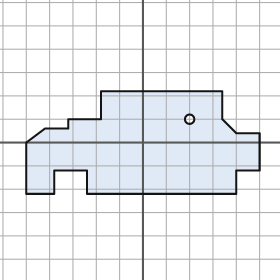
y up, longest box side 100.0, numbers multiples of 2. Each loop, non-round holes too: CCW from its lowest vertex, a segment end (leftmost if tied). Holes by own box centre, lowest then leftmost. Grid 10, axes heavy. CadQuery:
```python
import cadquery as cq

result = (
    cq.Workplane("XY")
    .moveTo(-50.0, -22.0)
    .lineTo(-38.0, -22.0)
    .lineTo(-38.0, -12.0)
    .lineTo(-24.0, -12.0)
    .lineTo(-24.0, -22.0)
    .lineTo(40.0, -22.0)
    .lineTo(40.0, -12.0)
    .lineTo(50.0, -12.0)
    .lineTo(50.0, 4.0)
    .lineTo(40.0, 4.0)
    .lineTo(34.0, 10.0)
    .lineTo(34.0, 22.0)
    .lineTo(-18.0, 22.0)
    .lineTo(-18.0, 10.0)
    .lineTo(-32.0, 10.0)
    .lineTo(-32.0, 6.0)
    .lineTo(-42.0, 6.0)
    .lineTo(-50.0, 0.0)
    .close()
    .moveTo(20.0, 10.0)
    .circle(2.0)
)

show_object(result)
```